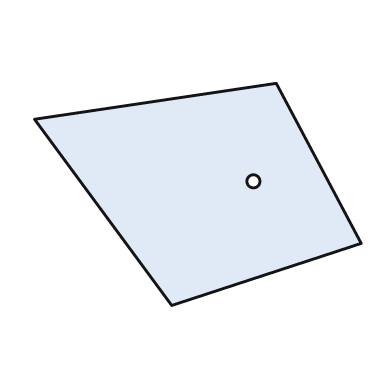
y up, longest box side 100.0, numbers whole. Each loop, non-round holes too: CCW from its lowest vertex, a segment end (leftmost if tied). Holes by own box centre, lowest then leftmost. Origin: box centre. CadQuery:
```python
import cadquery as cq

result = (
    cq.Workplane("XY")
    .moveTo(-8.0, -34.0)
    .lineTo(50.0, -15.0)
    .lineTo(24.0, 34.0)
    .lineTo(-50.0, 23.0)
    .close()
    .moveTo(17.0, 4.0)
    .circle(2.0)
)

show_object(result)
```